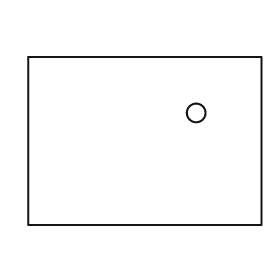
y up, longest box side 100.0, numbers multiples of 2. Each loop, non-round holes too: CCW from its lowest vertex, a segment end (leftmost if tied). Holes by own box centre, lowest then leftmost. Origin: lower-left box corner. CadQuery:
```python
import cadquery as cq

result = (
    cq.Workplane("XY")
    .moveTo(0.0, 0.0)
    .lineTo(100.0, 0.0)
    .lineTo(100.0, 72.0)
    .lineTo(0.0, 72.0)
    .close()
    .moveTo(72.0, 48.0)
    .circle(4.0)
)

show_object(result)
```